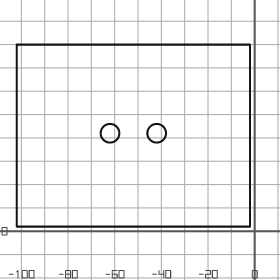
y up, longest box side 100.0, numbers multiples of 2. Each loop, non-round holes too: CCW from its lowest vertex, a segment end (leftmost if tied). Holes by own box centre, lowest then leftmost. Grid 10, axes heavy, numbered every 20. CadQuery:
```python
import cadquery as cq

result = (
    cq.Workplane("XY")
    .moveTo(-102.0, 2.0)
    .lineTo(-2.0, 2.0)
    .lineTo(-2.0, 80.0)
    .lineTo(-102.0, 80.0)
    .close()
    .moveTo(-62.0, 42.0)
    .circle(4.0)
    .moveTo(-42.0, 42.0)
    .circle(4.0)
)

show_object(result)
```